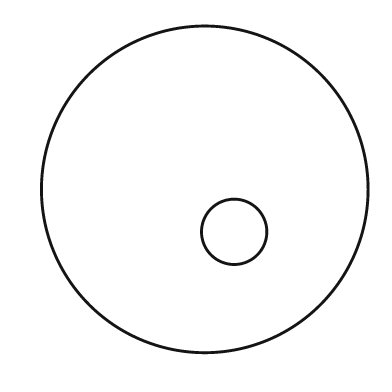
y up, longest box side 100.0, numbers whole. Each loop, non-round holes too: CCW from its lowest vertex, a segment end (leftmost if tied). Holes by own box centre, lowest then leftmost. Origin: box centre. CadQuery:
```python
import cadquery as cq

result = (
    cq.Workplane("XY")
    .moveTo(0.0, 0.0)
    .circle(50.0)
    .moveTo(9.0, -13.0)
    .circle(10.0)
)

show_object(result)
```